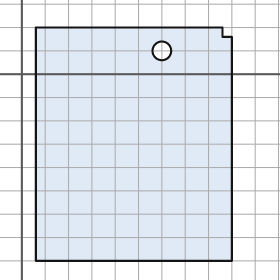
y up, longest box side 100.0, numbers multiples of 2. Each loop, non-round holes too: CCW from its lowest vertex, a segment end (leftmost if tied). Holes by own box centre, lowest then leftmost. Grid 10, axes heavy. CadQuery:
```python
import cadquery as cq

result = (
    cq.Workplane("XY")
    .moveTo(6.0, -80.0)
    .lineTo(90.0, -80.0)
    .lineTo(90.0, 16.0)
    .lineTo(86.0, 16.0)
    .lineTo(86.0, 20.0)
    .lineTo(6.0, 20.0)
    .close()
    .moveTo(60.0, 10.0)
    .circle(4.0)
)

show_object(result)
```